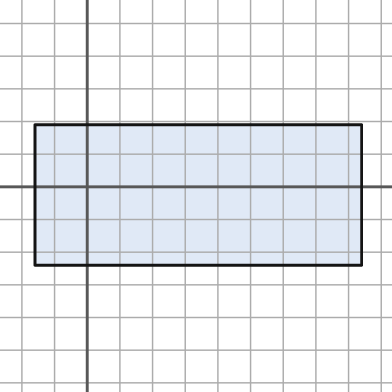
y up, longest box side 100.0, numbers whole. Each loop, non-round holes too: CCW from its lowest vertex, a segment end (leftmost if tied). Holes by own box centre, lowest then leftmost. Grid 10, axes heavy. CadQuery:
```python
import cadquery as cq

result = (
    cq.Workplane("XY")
    .moveTo(-16.0, -24.0)
    .lineTo(84.0, -24.0)
    .lineTo(84.0, 19.0)
    .lineTo(-16.0, 19.0)
    .close()
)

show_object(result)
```